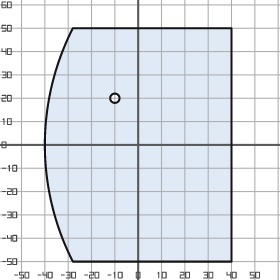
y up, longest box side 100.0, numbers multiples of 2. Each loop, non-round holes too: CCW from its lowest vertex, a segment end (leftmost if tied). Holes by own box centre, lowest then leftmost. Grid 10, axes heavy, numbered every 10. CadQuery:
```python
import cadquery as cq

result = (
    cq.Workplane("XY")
    .moveTo(-28.0, -50.0)
    .lineTo(40.0, -50.0)
    .lineTo(40.0, 50.0)
    .lineTo(-28.0, 50.0)
    .threePointArc((-40.0, 0.0), (-28.0, -50.0))
    .close()
    .moveTo(-10.0, 20.0)
    .circle(2.0)
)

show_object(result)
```